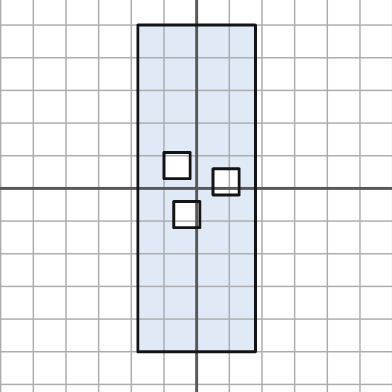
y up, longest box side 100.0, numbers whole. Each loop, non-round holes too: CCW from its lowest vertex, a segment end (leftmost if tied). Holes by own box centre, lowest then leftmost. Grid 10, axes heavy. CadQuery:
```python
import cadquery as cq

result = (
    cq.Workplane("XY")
    .moveTo(-18.0, -50.0)
    .lineTo(18.0, -50.0)
    .lineTo(18.0, 50.0)
    .lineTo(-18.0, 50.0)
    .close()
    .moveTo(-7.0, -12.0)
    .lineTo(1.0, -12.0)
    .lineTo(1.0, -4.0)
    .lineTo(-7.0, -4.0)
    .close()
    .moveTo(5.0, -2.0)
    .lineTo(13.0, -2.0)
    .lineTo(13.0, 6.0)
    .lineTo(5.0, 6.0)
    .close()
    .moveTo(-10.0, 3.0)
    .lineTo(-2.0, 3.0)
    .lineTo(-2.0, 11.0)
    .lineTo(-10.0, 11.0)
    .close()
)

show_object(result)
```